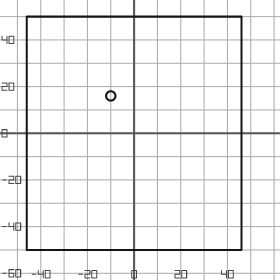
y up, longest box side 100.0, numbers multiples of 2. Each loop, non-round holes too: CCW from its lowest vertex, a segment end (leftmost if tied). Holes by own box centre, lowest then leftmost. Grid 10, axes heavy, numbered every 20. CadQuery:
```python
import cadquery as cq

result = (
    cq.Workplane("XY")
    .moveTo(-46.0, -50.0)
    .lineTo(46.0, -50.0)
    .lineTo(46.0, 50.0)
    .lineTo(-46.0, 50.0)
    .close()
    .moveTo(-10.0, 16.0)
    .circle(2.0)
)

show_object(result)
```